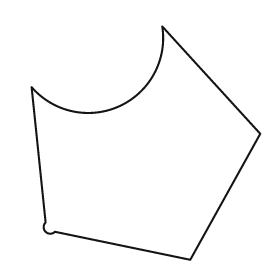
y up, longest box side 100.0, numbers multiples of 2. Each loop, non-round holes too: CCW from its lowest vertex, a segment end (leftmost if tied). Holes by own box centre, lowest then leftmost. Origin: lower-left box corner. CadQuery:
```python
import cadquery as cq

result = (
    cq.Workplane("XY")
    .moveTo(68.0, 0.0)
    .lineTo(98.0, 54.0)
    .lineTo(56.0, 100.0)
    .threePointArc((38.0, 66.0), (0.0, 74.0))
    .lineTo(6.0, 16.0)
    .threePointArc((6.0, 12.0), (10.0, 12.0))
    .close()
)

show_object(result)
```